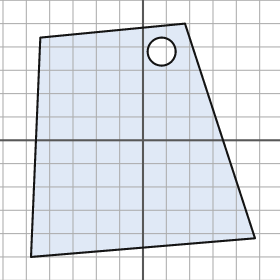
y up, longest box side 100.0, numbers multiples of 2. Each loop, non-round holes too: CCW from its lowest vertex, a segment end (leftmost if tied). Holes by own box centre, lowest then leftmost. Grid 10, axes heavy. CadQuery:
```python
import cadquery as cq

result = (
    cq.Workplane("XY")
    .moveTo(-48.0, -50.0)
    .lineTo(48.0, -42.0)
    .lineTo(18.0, 50.0)
    .lineTo(-44.0, 44.0)
    .close()
    .moveTo(8.0, 38.0)
    .circle(6.0)
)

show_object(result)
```